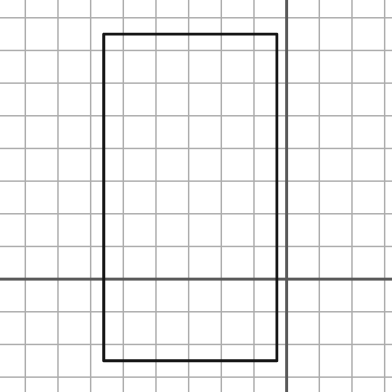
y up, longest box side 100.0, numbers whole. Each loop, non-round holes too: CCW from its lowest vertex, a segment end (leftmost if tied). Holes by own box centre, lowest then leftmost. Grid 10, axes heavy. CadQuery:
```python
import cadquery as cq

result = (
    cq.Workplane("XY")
    .moveTo(-56.0, -25.0)
    .lineTo(-3.0, -25.0)
    .lineTo(-3.0, 75.0)
    .lineTo(-56.0, 75.0)
    .close()
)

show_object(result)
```